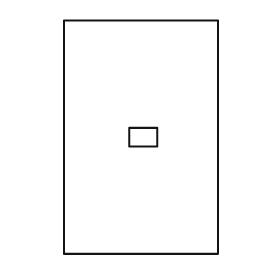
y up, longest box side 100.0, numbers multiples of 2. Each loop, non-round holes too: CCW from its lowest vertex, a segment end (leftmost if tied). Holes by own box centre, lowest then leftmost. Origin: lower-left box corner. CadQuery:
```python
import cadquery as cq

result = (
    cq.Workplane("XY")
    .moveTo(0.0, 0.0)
    .lineTo(66.0, 0.0)
    .lineTo(66.0, 100.0)
    .lineTo(0.0, 100.0)
    .close()
    .moveTo(28.0, 46.0)
    .lineTo(40.0, 46.0)
    .lineTo(40.0, 54.0)
    .lineTo(28.0, 54.0)
    .close()
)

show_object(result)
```